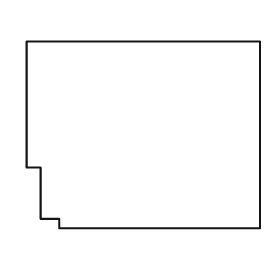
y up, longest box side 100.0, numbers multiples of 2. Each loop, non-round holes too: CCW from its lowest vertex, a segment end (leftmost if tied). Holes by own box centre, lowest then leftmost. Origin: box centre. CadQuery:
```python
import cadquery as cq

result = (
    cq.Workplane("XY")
    .moveTo(-36.0, -40.0)
    .lineTo(50.0, -40.0)
    .lineTo(50.0, 40.0)
    .lineTo(-50.0, 40.0)
    .lineTo(-50.0, -14.0)
    .lineTo(-44.0, -14.0)
    .lineTo(-44.0, -36.0)
    .lineTo(-36.0, -36.0)
    .close()
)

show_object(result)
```